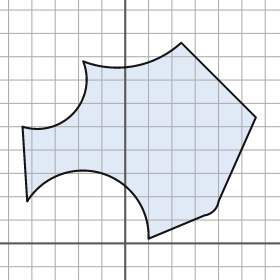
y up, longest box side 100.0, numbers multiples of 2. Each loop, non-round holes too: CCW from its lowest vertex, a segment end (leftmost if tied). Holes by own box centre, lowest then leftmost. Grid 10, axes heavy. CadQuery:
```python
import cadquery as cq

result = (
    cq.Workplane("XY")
    .moveTo(10.0, 2.0)
    .lineTo(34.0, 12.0)
    .threePointArc((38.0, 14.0), (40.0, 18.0))
    .lineTo(56.0, 54.0)
    .lineTo(24.0, 86.0)
    .threePointArc((4.0, 76.0), (-18.0, 78.0))
    .threePointArc((-22.0, 56.0), (-44.0, 50.0))
    .lineTo(-42.0, 18.0)
    .threePointArc((-10.0, 30.0), (10.0, 2.0))
    .close()
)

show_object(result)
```